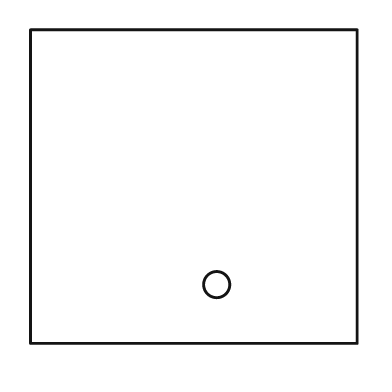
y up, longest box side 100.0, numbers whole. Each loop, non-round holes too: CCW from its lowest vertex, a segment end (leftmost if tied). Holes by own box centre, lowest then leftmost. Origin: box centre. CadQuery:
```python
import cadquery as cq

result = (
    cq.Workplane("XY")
    .moveTo(-50.0, -48.0)
    .lineTo(50.0, -48.0)
    .lineTo(50.0, 48.0)
    .lineTo(-50.0, 48.0)
    .close()
    .moveTo(7.0, -30.0)
    .circle(4.0)
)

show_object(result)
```